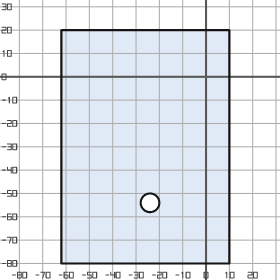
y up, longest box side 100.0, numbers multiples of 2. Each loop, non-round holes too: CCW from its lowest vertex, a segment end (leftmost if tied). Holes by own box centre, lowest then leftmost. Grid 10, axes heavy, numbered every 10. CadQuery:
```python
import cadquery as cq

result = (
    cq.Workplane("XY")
    .moveTo(-62.0, -80.0)
    .lineTo(10.0, -80.0)
    .lineTo(10.0, 20.0)
    .lineTo(-62.0, 20.0)
    .close()
    .moveTo(-24.0, -54.0)
    .circle(4.0)
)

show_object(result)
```